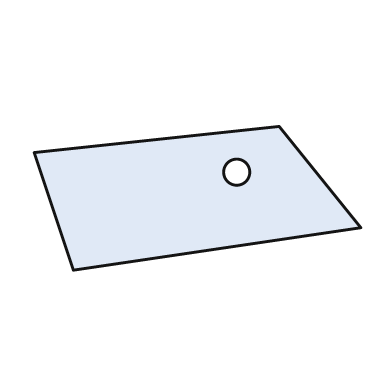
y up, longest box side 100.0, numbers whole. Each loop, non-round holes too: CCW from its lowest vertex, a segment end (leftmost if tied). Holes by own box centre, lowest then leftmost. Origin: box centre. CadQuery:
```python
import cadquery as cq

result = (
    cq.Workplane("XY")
    .moveTo(-38.0, -22.0)
    .lineTo(50.0, -9.0)
    .lineTo(25.0, 22.0)
    .lineTo(-50.0, 14.0)
    .close()
    .moveTo(12.0, 8.0)
    .circle(4.0)
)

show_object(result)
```